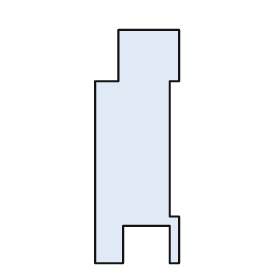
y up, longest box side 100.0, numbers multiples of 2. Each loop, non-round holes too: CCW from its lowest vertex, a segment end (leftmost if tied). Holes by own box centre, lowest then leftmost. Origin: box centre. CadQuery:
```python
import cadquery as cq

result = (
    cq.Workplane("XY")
    .moveTo(-18.0, -50.0)
    .lineTo(-6.0, -50.0)
    .lineTo(-6.0, -34.0)
    .lineTo(14.0, -34.0)
    .lineTo(14.0, -50.0)
    .lineTo(18.0, -50.0)
    .lineTo(18.0, -30.0)
    .lineTo(14.0, -30.0)
    .lineTo(14.0, 28.0)
    .lineTo(18.0, 28.0)
    .lineTo(18.0, 50.0)
    .lineTo(-8.0, 50.0)
    .lineTo(-8.0, 28.0)
    .lineTo(-18.0, 28.0)
    .close()
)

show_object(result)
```